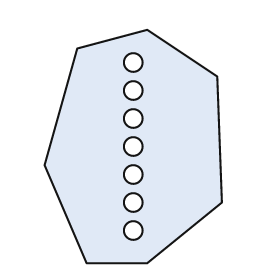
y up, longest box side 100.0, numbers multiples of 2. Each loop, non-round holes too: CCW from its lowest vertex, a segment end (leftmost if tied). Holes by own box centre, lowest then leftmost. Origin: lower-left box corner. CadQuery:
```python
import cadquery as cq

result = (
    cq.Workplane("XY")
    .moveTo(18.0, 0.0)
    .lineTo(44.0, 0.0)
    .lineTo(76.0, 26.0)
    .lineTo(74.0, 80.0)
    .lineTo(44.0, 100.0)
    .lineTo(14.0, 92.0)
    .lineTo(0.0, 42.0)
    .close()
    .moveTo(38.0, 14.0)
    .circle(4.0)
    .moveTo(38.0, 26.0)
    .circle(4.0)
    .moveTo(38.0, 38.0)
    .circle(4.0)
    .moveTo(38.0, 50.0)
    .circle(4.0)
    .moveTo(38.0, 62.0)
    .circle(4.0)
    .moveTo(38.0, 74.0)
    .circle(4.0)
    .moveTo(38.0, 86.0)
    .circle(4.0)
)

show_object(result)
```